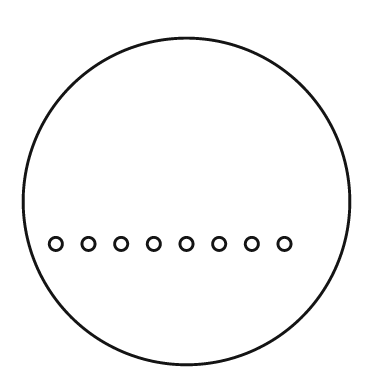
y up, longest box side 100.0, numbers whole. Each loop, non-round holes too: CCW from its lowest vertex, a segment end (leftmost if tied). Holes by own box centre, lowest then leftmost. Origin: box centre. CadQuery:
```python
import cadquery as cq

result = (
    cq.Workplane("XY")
    .moveTo(0.0, 0.0)
    .circle(50.0)
    .moveTo(-40.0, -13.0)
    .circle(2.0)
    .moveTo(-30.0, -13.0)
    .circle(2.0)
    .moveTo(-20.0, -13.0)
    .circle(2.0)
    .moveTo(-10.0, -13.0)
    .circle(2.0)
    .moveTo(0.0, -13.0)
    .circle(2.0)
    .moveTo(10.0, -13.0)
    .circle(2.0)
    .moveTo(20.0, -13.0)
    .circle(2.0)
    .moveTo(30.0, -13.0)
    .circle(2.0)
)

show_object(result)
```